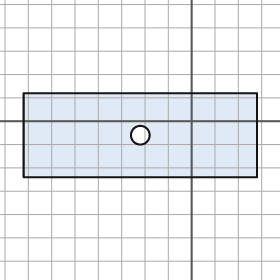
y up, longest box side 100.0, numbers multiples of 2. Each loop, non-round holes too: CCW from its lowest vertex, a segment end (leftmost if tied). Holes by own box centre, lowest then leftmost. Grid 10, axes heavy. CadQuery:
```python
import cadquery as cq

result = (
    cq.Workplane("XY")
    .moveTo(-72.0, -24.0)
    .lineTo(28.0, -24.0)
    .lineTo(28.0, 12.0)
    .lineTo(-72.0, 12.0)
    .close()
    .moveTo(-22.0, -6.0)
    .circle(4.0)
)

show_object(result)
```